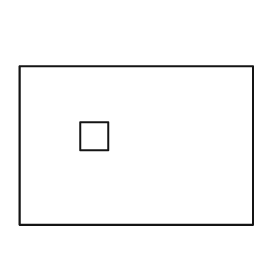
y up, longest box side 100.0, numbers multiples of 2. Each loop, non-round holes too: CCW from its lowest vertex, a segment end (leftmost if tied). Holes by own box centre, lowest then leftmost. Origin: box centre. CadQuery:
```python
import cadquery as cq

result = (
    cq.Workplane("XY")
    .moveTo(-50.0, -34.0)
    .lineTo(50.0, -34.0)
    .lineTo(50.0, 34.0)
    .lineTo(-50.0, 34.0)
    .close()
    .moveTo(-24.0, -2.0)
    .lineTo(-12.0, -2.0)
    .lineTo(-12.0, 10.0)
    .lineTo(-24.0, 10.0)
    .close()
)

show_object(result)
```